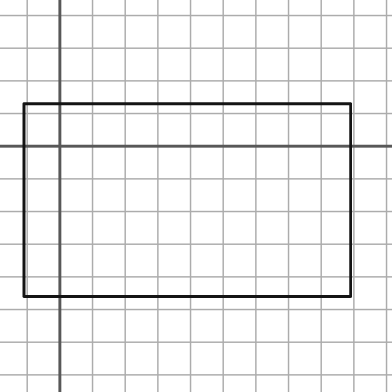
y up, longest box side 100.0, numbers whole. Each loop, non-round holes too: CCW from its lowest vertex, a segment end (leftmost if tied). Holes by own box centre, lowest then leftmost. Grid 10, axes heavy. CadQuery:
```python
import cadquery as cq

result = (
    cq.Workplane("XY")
    .moveTo(-11.0, -46.0)
    .lineTo(89.0, -46.0)
    .lineTo(89.0, 13.0)
    .lineTo(-11.0, 13.0)
    .close()
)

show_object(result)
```